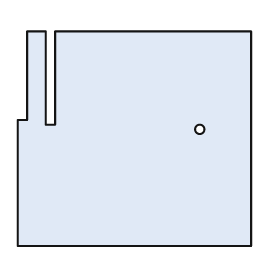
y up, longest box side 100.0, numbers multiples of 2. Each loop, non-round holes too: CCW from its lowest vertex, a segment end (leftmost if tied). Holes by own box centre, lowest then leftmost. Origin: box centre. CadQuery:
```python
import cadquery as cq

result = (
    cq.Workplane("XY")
    .moveTo(-50.0, -46.0)
    .lineTo(50.0, -46.0)
    .lineTo(50.0, 46.0)
    .lineTo(-34.0, 46.0)
    .lineTo(-34.0, 6.0)
    .lineTo(-38.0, 6.0)
    .lineTo(-38.0, 46.0)
    .lineTo(-46.0, 46.0)
    .lineTo(-46.0, 8.0)
    .lineTo(-50.0, 8.0)
    .close()
    .moveTo(28.0, 4.0)
    .circle(2.0)
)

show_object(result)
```